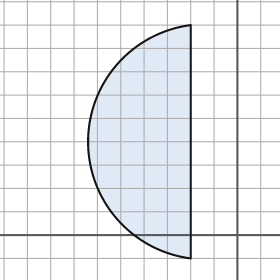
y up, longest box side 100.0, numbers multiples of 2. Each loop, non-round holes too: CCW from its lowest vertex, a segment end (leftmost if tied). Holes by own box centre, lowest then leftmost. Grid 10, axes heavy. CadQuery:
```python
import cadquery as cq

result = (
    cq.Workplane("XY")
    .moveTo(-20.0, -10.0)
    .lineTo(-20.0, 90.0)
    .threePointArc((-64.0, 40.0), (-20.0, -10.0))
    .close()
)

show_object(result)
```